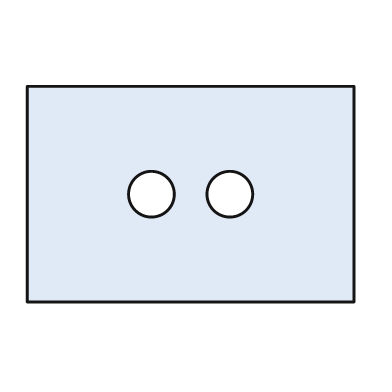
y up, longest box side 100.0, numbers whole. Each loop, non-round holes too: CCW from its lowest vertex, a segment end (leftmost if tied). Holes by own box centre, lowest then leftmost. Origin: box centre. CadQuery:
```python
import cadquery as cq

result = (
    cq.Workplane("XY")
    .moveTo(-50.0, -33.0)
    .lineTo(50.0, -33.0)
    .lineTo(50.0, 33.0)
    .lineTo(-50.0, 33.0)
    .close()
    .moveTo(-12.0, 0.0)
    .circle(7.0)
    .moveTo(12.0, 0.0)
    .circle(7.0)
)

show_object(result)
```